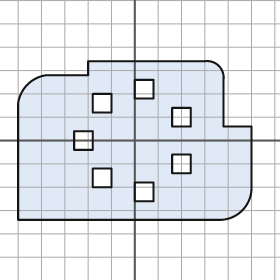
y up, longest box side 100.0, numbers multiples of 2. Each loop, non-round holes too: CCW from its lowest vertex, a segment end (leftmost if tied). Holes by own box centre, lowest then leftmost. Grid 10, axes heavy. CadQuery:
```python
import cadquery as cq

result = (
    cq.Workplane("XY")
    .moveTo(-50.0, -34.0)
    .lineTo(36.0, -34.0)
    .threePointArc((46.0, -30.0), (50.0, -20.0))
    .lineTo(50.0, 6.0)
    .lineTo(38.0, 6.0)
    .lineTo(38.0, 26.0)
    .threePointArc((36.0, 32.0), (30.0, 34.0))
    .lineTo(-20.0, 34.0)
    .lineTo(-20.0, 28.0)
    .lineTo(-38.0, 28.0)
    .threePointArc((-46.0, 24.0), (-50.0, 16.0))
    .close()
    .moveTo(0.0, -26.0)
    .lineTo(8.0, -26.0)
    .lineTo(8.0, -18.0)
    .lineTo(0.0, -18.0)
    .close()
    .moveTo(-18.0, -20.0)
    .lineTo(-10.0, -20.0)
    .lineTo(-10.0, -12.0)
    .lineTo(-18.0, -12.0)
    .close()
    .moveTo(16.0, -14.0)
    .lineTo(24.0, -14.0)
    .lineTo(24.0, -6.0)
    .lineTo(16.0, -6.0)
    .close()
    .moveTo(-26.0, -4.0)
    .lineTo(-18.0, -4.0)
    .lineTo(-18.0, 4.0)
    .lineTo(-26.0, 4.0)
    .close()
    .moveTo(16.0, 6.0)
    .lineTo(24.0, 6.0)
    .lineTo(24.0, 14.0)
    .lineTo(16.0, 14.0)
    .close()
    .moveTo(-18.0, 12.0)
    .lineTo(-10.0, 12.0)
    .lineTo(-10.0, 20.0)
    .lineTo(-18.0, 20.0)
    .close()
    .moveTo(0.0, 18.0)
    .lineTo(8.0, 18.0)
    .lineTo(8.0, 26.0)
    .lineTo(0.0, 26.0)
    .close()
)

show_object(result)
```